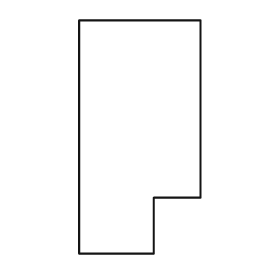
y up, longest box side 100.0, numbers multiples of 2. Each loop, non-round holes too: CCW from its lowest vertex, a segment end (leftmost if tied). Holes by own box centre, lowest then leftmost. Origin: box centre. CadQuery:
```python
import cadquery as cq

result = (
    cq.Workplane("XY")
    .moveTo(-26.0, -50.0)
    .lineTo(6.0, -50.0)
    .lineTo(6.0, -26.0)
    .lineTo(26.0, -26.0)
    .lineTo(26.0, 50.0)
    .lineTo(-26.0, 50.0)
    .close()
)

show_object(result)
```